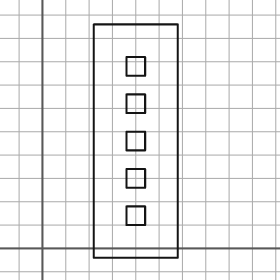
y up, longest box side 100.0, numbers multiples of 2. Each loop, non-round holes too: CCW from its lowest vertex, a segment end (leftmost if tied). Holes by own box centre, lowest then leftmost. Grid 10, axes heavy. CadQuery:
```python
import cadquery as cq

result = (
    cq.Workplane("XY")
    .moveTo(22.0, -4.0)
    .lineTo(58.0, -4.0)
    .lineTo(58.0, 96.0)
    .lineTo(22.0, 96.0)
    .close()
    .moveTo(36.0, 10.0)
    .lineTo(44.0, 10.0)
    .lineTo(44.0, 18.0)
    .lineTo(36.0, 18.0)
    .close()
    .moveTo(36.0, 26.0)
    .lineTo(44.0, 26.0)
    .lineTo(44.0, 34.0)
    .lineTo(36.0, 34.0)
    .close()
    .moveTo(36.0, 42.0)
    .lineTo(44.0, 42.0)
    .lineTo(44.0, 50.0)
    .lineTo(36.0, 50.0)
    .close()
    .moveTo(36.0, 58.0)
    .lineTo(44.0, 58.0)
    .lineTo(44.0, 66.0)
    .lineTo(36.0, 66.0)
    .close()
    .moveTo(36.0, 74.0)
    .lineTo(44.0, 74.0)
    .lineTo(44.0, 82.0)
    .lineTo(36.0, 82.0)
    .close()
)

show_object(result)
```